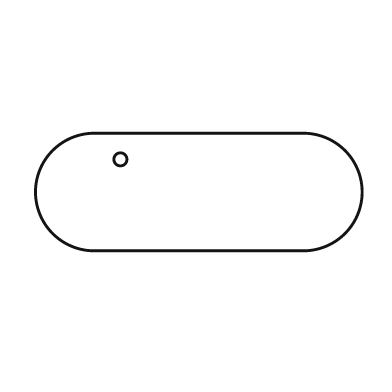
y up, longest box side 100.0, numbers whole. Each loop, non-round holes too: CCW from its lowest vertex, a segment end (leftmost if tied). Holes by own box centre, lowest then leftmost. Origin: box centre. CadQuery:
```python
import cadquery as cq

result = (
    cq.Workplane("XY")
    .moveTo(-32.0, -18.0)
    .lineTo(32.0, -18.0)
    .threePointArc((50.0, 0.0), (32.0, 18.0))
    .lineTo(-32.0, 18.0)
    .threePointArc((-50.0, 0.0), (-32.0, -18.0))
    .close()
    .moveTo(-24.0, 10.0)
    .circle(2.0)
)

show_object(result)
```